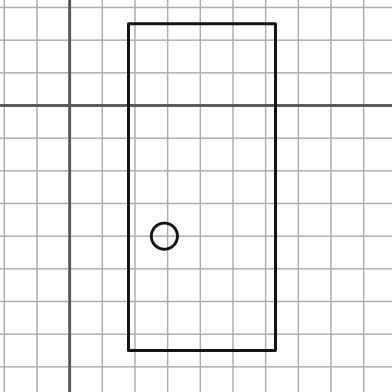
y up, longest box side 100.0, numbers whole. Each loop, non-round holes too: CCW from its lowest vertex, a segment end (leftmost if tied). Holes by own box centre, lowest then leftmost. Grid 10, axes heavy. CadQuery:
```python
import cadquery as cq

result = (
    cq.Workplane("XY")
    .moveTo(18.0, -75.0)
    .lineTo(63.0, -75.0)
    .lineTo(63.0, 25.0)
    .lineTo(18.0, 25.0)
    .close()
    .moveTo(29.0, -40.0)
    .circle(4.0)
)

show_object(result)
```